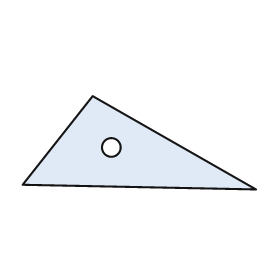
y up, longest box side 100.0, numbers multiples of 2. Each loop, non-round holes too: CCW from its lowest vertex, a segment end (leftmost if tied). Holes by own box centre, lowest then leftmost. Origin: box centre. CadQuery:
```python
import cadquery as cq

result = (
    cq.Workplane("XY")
    .moveTo(50.0, -20.0)
    .lineTo(-20.0, 20.0)
    .lineTo(-50.0, -18.0)
    .close()
    .moveTo(-12.0, -2.0)
    .circle(4.0)
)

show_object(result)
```